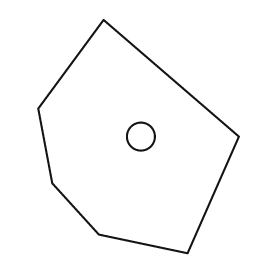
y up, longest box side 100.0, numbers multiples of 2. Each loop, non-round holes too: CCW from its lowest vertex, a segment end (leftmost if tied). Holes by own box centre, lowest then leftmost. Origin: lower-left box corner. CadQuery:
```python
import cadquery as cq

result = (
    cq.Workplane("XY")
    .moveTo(64.0, 0.0)
    .lineTo(86.0, 50.0)
    .lineTo(28.0, 100.0)
    .lineTo(0.0, 62.0)
    .lineTo(6.0, 30.0)
    .lineTo(26.0, 8.0)
    .close()
    .moveTo(44.0, 50.0)
    .circle(6.0)
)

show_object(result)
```